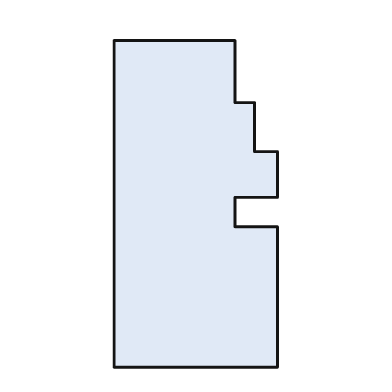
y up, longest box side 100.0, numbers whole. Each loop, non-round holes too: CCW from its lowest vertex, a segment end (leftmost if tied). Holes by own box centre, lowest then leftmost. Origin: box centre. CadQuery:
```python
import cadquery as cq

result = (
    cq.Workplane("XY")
    .moveTo(-25.0, -50.0)
    .lineTo(25.0, -50.0)
    .lineTo(25.0, -7.0)
    .lineTo(12.0, -7.0)
    .lineTo(12.0, 2.0)
    .lineTo(25.0, 2.0)
    .lineTo(25.0, 16.0)
    .lineTo(18.0, 16.0)
    .lineTo(18.0, 31.0)
    .lineTo(12.0, 31.0)
    .lineTo(12.0, 50.0)
    .lineTo(-25.0, 50.0)
    .close()
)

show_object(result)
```